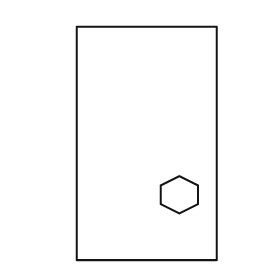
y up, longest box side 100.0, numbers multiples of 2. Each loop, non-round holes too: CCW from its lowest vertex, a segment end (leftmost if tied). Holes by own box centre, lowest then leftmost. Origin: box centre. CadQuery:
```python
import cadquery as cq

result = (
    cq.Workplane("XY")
    .moveTo(-30.0, -50.0)
    .lineTo(30.0, -50.0)
    .lineTo(30.0, 50.0)
    .lineTo(-30.0, 50.0)
    .close()
    .moveTo(14.0, -30.0)
    .lineTo(22.0, -26.0)
    .lineTo(22.0, -18.0)
    .lineTo(14.0, -14.0)
    .lineTo(6.0, -18.0)
    .lineTo(6.0, -26.0)
    .close()
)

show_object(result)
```